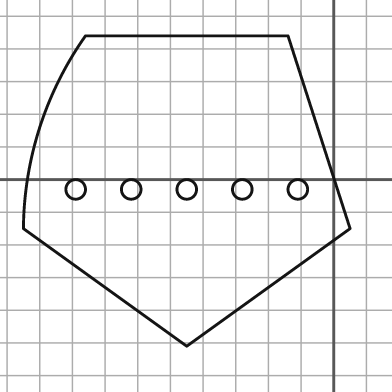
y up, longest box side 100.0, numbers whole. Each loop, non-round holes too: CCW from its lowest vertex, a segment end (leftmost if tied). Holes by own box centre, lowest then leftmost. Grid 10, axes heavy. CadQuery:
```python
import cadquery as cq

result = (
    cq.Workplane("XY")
    .moveTo(-45.0, -51.0)
    .lineTo(5.0, -15.0)
    .lineTo(-14.0, 44.0)
    .lineTo(-76.0, 44.0)
    .threePointArc((-90.0, 16.0), (-95.0, -15.0))
    .close()
    .moveTo(-79.0, -3.0)
    .circle(3.0)
    .moveTo(-62.0, -3.0)
    .circle(3.0)
    .moveTo(-45.0, -3.0)
    .circle(3.0)
    .moveTo(-28.0, -3.0)
    .circle(3.0)
    .moveTo(-11.0, -3.0)
    .circle(3.0)
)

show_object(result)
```